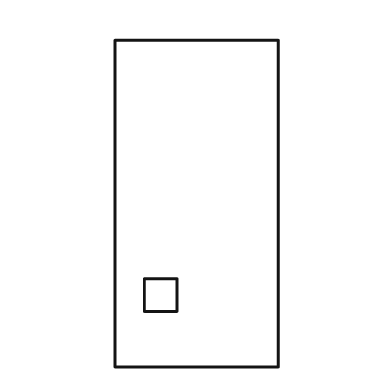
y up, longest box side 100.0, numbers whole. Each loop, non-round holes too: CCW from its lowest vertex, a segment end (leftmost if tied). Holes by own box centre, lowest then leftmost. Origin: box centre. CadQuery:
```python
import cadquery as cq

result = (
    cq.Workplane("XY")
    .moveTo(-25.0, -50.0)
    .lineTo(25.0, -50.0)
    .lineTo(25.0, 50.0)
    .lineTo(-25.0, 50.0)
    .close()
    .moveTo(-16.0, -33.0)
    .lineTo(-6.0, -33.0)
    .lineTo(-6.0, -23.0)
    .lineTo(-16.0, -23.0)
    .close()
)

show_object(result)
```